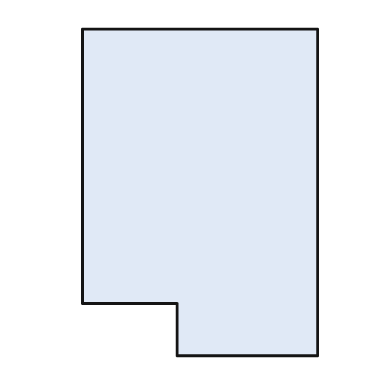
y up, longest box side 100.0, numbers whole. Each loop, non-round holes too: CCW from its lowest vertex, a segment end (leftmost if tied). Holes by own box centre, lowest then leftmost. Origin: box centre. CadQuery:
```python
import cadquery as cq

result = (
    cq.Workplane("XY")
    .moveTo(-7.0, -50.0)
    .lineTo(36.0, -50.0)
    .lineTo(36.0, 50.0)
    .lineTo(-36.0, 50.0)
    .lineTo(-36.0, -34.0)
    .lineTo(-7.0, -34.0)
    .close()
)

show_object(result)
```